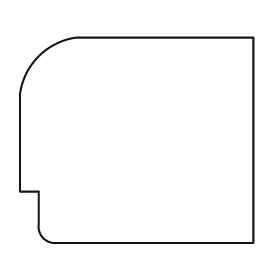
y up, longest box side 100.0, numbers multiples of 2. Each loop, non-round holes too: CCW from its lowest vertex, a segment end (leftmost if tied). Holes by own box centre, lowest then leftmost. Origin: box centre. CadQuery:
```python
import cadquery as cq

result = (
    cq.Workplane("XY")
    .moveTo(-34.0, -44.0)
    .lineTo(50.0, -44.0)
    .lineTo(50.0, 44.0)
    .lineTo(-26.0, 44.0)
    .threePointArc((-42.0, 36.0), (-50.0, 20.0))
    .lineTo(-50.0, -22.0)
    .lineTo(-42.0, -22.0)
    .lineTo(-42.0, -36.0)
    .threePointArc((-40.0, -42.0), (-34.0, -44.0))
    .close()
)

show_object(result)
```